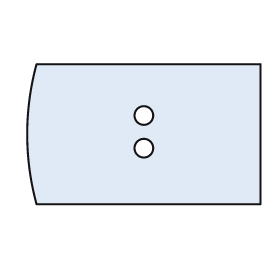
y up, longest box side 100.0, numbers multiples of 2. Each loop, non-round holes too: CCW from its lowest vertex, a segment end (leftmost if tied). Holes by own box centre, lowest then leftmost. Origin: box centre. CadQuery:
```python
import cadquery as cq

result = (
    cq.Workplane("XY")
    .moveTo(-46.0, -30.0)
    .lineTo(50.0, -30.0)
    .lineTo(50.0, 30.0)
    .lineTo(-46.0, 30.0)
    .threePointArc((-50.0, 0.0), (-46.0, -30.0))
    .close()
    .moveTo(0.0, -6.0)
    .circle(4.0)
    .moveTo(0.0, 8.0)
    .circle(4.0)
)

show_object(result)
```